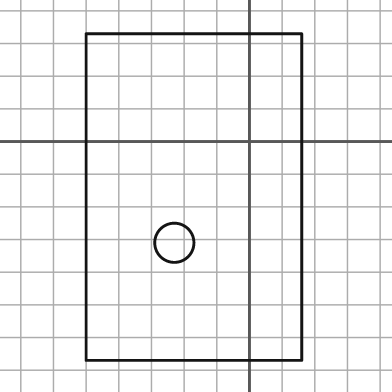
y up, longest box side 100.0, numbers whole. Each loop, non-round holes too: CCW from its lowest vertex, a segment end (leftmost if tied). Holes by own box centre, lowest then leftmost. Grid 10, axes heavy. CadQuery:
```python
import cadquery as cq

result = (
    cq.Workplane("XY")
    .moveTo(-50.0, -67.0)
    .lineTo(16.0, -67.0)
    .lineTo(16.0, 33.0)
    .lineTo(-50.0, 33.0)
    .close()
    .moveTo(-23.0, -31.0)
    .circle(6.0)
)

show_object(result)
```